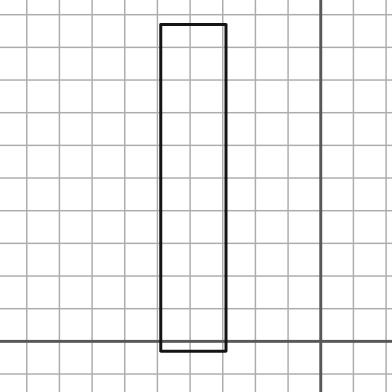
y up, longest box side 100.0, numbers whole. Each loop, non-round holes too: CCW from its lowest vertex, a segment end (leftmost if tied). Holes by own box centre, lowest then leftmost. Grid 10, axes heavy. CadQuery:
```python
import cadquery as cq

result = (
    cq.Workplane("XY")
    .moveTo(-49.0, -3.0)
    .lineTo(-29.0, -3.0)
    .lineTo(-29.0, 97.0)
    .lineTo(-49.0, 97.0)
    .close()
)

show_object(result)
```